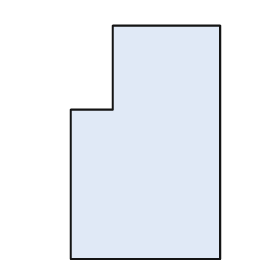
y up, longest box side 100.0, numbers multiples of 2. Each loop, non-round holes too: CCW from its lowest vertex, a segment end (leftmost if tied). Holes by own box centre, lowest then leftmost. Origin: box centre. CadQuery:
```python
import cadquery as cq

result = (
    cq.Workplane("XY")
    .moveTo(-32.0, -50.0)
    .lineTo(32.0, -50.0)
    .lineTo(32.0, 50.0)
    .lineTo(-14.0, 50.0)
    .lineTo(-14.0, 14.0)
    .lineTo(-32.0, 14.0)
    .close()
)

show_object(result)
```